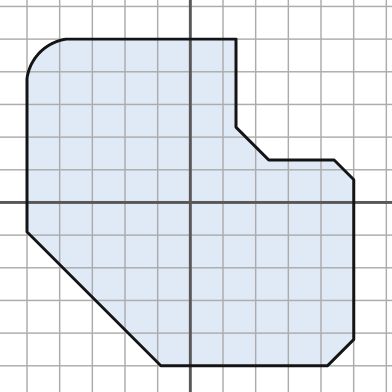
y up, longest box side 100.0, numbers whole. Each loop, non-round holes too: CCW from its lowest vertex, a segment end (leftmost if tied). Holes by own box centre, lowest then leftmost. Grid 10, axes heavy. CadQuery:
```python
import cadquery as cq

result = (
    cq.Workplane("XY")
    .moveTo(-9.0, -50.0)
    .lineTo(42.0, -50.0)
    .lineTo(50.0, -42.0)
    .lineTo(50.0, 7.0)
    .lineTo(44.0, 13.0)
    .lineTo(24.0, 13.0)
    .lineTo(14.0, 23.0)
    .lineTo(14.0, 50.0)
    .lineTo(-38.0, 50.0)
    .threePointArc((-46.0, 46.0), (-50.0, 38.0))
    .lineTo(-50.0, -9.0)
    .close()
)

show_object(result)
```